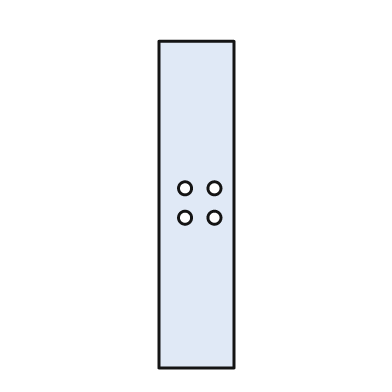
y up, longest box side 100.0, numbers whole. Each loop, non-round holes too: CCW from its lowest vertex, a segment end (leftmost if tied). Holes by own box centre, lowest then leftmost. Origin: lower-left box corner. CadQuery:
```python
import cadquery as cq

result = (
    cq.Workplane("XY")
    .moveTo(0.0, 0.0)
    .lineTo(23.0, 0.0)
    .lineTo(23.0, 100.0)
    .lineTo(0.0, 100.0)
    .close()
    .moveTo(8.0, 46.0)
    .circle(2.0)
    .moveTo(17.0, 46.0)
    .circle(2.0)
    .moveTo(8.0, 55.0)
    .circle(2.0)
    .moveTo(17.0, 55.0)
    .circle(2.0)
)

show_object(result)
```